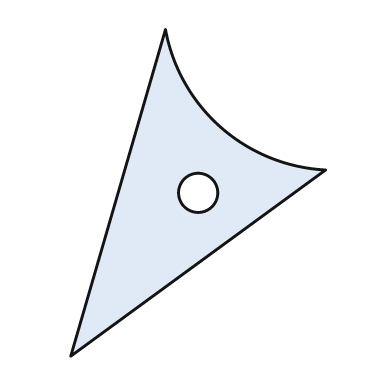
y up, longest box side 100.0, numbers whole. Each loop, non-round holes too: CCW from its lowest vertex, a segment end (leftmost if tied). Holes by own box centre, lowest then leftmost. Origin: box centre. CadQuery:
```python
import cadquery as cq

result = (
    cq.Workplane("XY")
    .moveTo(-39.0, -50.0)
    .lineTo(39.0, 7.0)
    .threePointArc((7.0, 20.0), (-10.0, 50.0))
    .close()
    .moveTo(0.0, 0.0)
    .circle(6.0)
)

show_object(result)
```